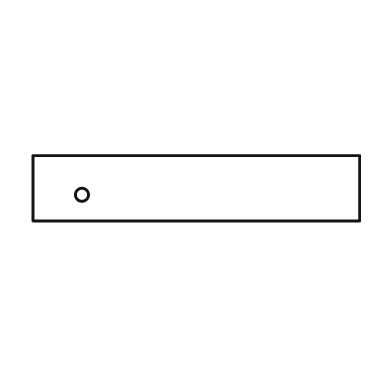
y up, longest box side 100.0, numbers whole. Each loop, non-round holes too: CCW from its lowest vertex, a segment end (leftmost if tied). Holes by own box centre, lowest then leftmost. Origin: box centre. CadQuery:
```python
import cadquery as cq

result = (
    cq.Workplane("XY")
    .moveTo(-50.0, -10.0)
    .lineTo(50.0, -10.0)
    .lineTo(50.0, 10.0)
    .lineTo(-50.0, 10.0)
    .close()
    .moveTo(-35.0, -2.0)
    .circle(2.0)
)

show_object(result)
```